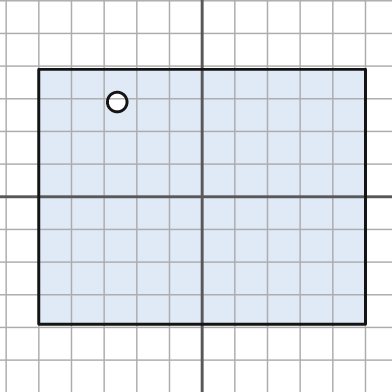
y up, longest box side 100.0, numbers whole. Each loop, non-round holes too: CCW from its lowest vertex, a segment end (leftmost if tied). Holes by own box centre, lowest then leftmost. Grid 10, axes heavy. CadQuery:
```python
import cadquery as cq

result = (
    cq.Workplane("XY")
    .moveTo(-50.0, -39.0)
    .lineTo(50.0, -39.0)
    .lineTo(50.0, 39.0)
    .lineTo(-50.0, 39.0)
    .close()
    .moveTo(-26.0, 29.0)
    .circle(3.0)
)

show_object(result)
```